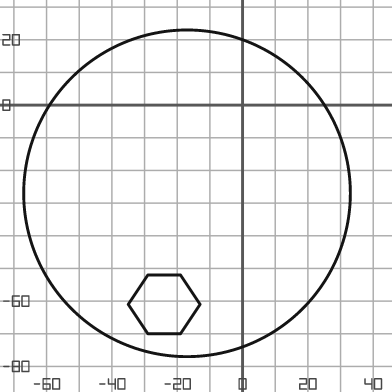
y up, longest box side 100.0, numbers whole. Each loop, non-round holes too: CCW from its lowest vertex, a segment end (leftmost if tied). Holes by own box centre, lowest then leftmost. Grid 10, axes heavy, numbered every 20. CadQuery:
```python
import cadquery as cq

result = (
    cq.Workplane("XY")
    .moveTo(-17.0, -27.0)
    .circle(50.0)
    .moveTo(-29.0, -70.0)
    .lineTo(-19.0, -70.0)
    .lineTo(-13.0, -61.0)
    .lineTo(-19.0, -52.0)
    .lineTo(-29.0, -52.0)
    .lineTo(-35.0, -61.0)
    .close()
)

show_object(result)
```